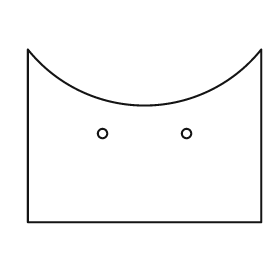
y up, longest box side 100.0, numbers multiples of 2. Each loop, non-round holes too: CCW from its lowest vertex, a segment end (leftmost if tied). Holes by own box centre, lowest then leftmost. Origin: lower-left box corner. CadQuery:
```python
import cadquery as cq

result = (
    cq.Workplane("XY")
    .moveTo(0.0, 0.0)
    .lineTo(100.0, 0.0)
    .lineTo(100.0, 74.0)
    .threePointArc((50.0, 50.0), (0.0, 74.0))
    .close()
    .moveTo(32.0, 38.0)
    .circle(2.0)
    .moveTo(68.0, 38.0)
    .circle(2.0)
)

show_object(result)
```